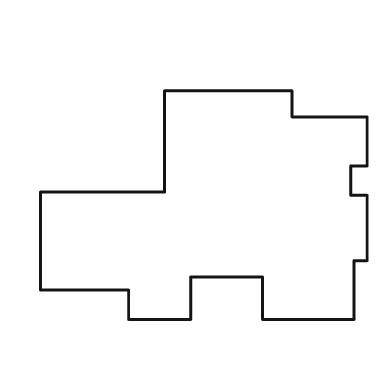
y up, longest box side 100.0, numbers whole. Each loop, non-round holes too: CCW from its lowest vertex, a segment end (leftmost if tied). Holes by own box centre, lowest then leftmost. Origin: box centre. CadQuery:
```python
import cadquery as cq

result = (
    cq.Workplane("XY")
    .moveTo(-23.0, -35.0)
    .lineTo(-4.0, -35.0)
    .lineTo(-4.0, -22.0)
    .lineTo(18.0, -22.0)
    .lineTo(18.0, -35.0)
    .lineTo(46.0, -35.0)
    .lineTo(46.0, -17.0)
    .lineTo(50.0, -17.0)
    .lineTo(50.0, 3.0)
    .lineTo(45.0, 3.0)
    .lineTo(45.0, 12.0)
    .lineTo(50.0, 12.0)
    .lineTo(50.0, 27.0)
    .lineTo(27.0, 27.0)
    .lineTo(27.0, 35.0)
    .lineTo(-12.0, 35.0)
    .lineTo(-12.0, 4.0)
    .lineTo(-50.0, 4.0)
    .lineTo(-50.0, -26.0)
    .lineTo(-23.0, -26.0)
    .close()
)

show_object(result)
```